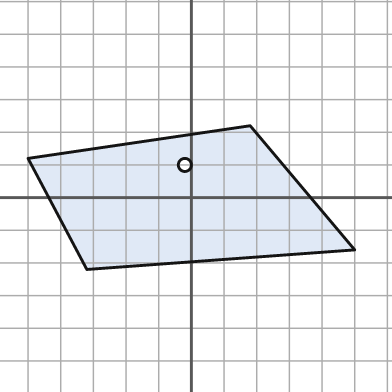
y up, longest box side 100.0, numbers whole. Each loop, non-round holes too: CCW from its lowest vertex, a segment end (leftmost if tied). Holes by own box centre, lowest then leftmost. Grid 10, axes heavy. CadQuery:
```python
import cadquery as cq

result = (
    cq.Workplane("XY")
    .moveTo(-32.0, -22.0)
    .lineTo(50.0, -16.0)
    .lineTo(18.0, 22.0)
    .lineTo(-50.0, 12.0)
    .close()
    .moveTo(-2.0, 10.0)
    .circle(2.0)
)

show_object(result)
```